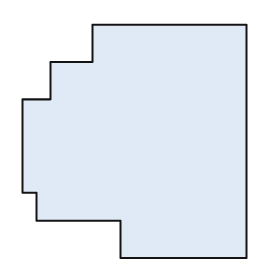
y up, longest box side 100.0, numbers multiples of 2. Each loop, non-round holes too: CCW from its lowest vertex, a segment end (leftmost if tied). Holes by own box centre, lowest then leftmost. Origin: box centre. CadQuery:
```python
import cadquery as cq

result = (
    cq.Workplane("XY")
    .moveTo(-6.0, -50.0)
    .lineTo(48.0, -50.0)
    .lineTo(48.0, 50.0)
    .lineTo(-18.0, 50.0)
    .lineTo(-18.0, 34.0)
    .lineTo(-36.0, 34.0)
    .lineTo(-36.0, 18.0)
    .lineTo(-48.0, 18.0)
    .lineTo(-48.0, -22.0)
    .lineTo(-42.0, -22.0)
    .lineTo(-42.0, -34.0)
    .lineTo(-6.0, -34.0)
    .close()
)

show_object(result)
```